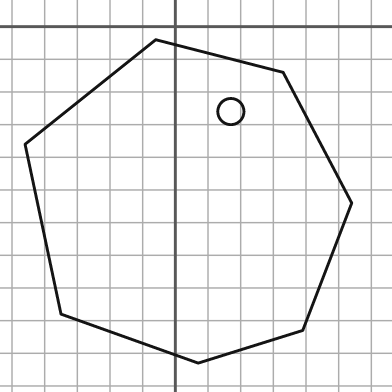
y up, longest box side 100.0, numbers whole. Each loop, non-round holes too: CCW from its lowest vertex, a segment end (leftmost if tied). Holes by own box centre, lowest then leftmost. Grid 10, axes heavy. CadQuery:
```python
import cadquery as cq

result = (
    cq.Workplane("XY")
    .moveTo(7.0, -103.0)
    .lineTo(39.0, -93.0)
    .lineTo(54.0, -54.0)
    .lineTo(33.0, -14.0)
    .lineTo(-6.0, -4.0)
    .lineTo(-46.0, -36.0)
    .lineTo(-35.0, -88.0)
    .close()
    .moveTo(17.0, -26.0)
    .circle(4.0)
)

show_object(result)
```